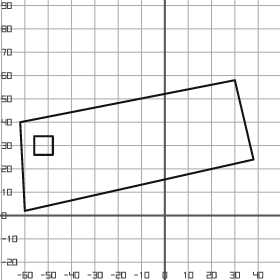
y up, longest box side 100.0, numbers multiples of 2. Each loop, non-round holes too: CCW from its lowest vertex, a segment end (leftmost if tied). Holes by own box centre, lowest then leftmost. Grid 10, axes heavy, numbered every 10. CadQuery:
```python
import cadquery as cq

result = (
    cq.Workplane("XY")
    .moveTo(-60.0, 2.0)
    .lineTo(38.0, 24.0)
    .lineTo(30.0, 58.0)
    .lineTo(-62.0, 40.0)
    .close()
    .moveTo(-56.0, 26.0)
    .lineTo(-48.0, 26.0)
    .lineTo(-48.0, 34.0)
    .lineTo(-56.0, 34.0)
    .close()
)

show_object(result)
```